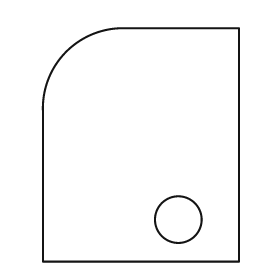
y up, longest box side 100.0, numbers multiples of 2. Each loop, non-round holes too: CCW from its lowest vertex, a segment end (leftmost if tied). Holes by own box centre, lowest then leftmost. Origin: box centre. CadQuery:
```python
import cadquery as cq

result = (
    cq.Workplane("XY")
    .moveTo(-42.0, -50.0)
    .lineTo(42.0, -50.0)
    .lineTo(42.0, 50.0)
    .lineTo(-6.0, 50.0)
    .threePointArc((-32.0, 40.0), (-42.0, 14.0))
    .close()
    .moveTo(16.0, -32.0)
    .circle(10.0)
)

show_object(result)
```